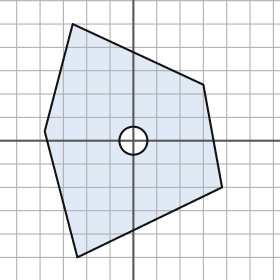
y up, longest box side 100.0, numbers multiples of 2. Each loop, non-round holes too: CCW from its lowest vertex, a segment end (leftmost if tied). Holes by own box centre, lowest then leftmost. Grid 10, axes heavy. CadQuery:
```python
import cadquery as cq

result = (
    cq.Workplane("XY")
    .moveTo(-24.0, -50.0)
    .lineTo(38.0, -20.0)
    .lineTo(30.0, 24.0)
    .lineTo(-26.0, 50.0)
    .lineTo(-38.0, 4.0)
    .close()
    .moveTo(0.0, 0.0)
    .circle(6.0)
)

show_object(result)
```